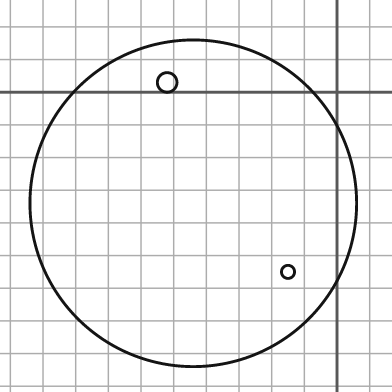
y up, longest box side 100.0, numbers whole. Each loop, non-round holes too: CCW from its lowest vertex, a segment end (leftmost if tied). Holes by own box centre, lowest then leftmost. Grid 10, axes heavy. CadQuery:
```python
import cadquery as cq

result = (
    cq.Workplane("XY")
    .moveTo(-44.0, -34.0)
    .circle(50.0)
    .moveTo(-15.0, -55.0)
    .circle(2.0)
    .moveTo(-52.0, 3.0)
    .circle(3.0)
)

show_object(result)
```